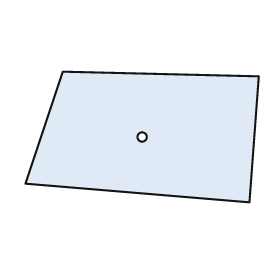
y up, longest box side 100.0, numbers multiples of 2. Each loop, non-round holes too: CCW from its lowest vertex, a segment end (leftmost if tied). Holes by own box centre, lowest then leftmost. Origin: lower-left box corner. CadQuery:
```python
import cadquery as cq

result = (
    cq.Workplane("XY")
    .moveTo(96.0, 0.0)
    .lineTo(100.0, 54.0)
    .lineTo(16.0, 56.0)
    .lineTo(0.0, 8.0)
    .close()
    .moveTo(50.0, 28.0)
    .circle(2.0)
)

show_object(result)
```